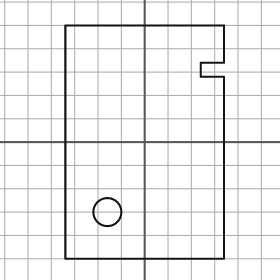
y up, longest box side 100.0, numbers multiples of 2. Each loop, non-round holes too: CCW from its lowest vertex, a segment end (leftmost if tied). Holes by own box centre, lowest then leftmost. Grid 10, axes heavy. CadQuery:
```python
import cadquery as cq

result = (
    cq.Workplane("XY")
    .moveTo(-34.0, -50.0)
    .lineTo(34.0, -50.0)
    .lineTo(34.0, 28.0)
    .lineTo(24.0, 28.0)
    .lineTo(24.0, 34.0)
    .lineTo(34.0, 34.0)
    .lineTo(34.0, 50.0)
    .lineTo(-34.0, 50.0)
    .close()
    .moveTo(-16.0, -30.0)
    .circle(6.0)
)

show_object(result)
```